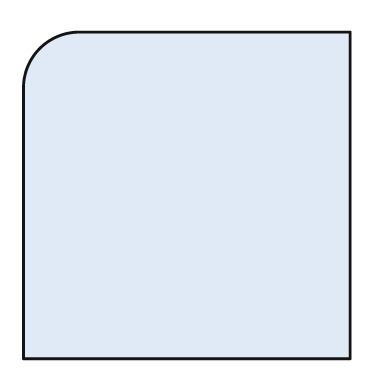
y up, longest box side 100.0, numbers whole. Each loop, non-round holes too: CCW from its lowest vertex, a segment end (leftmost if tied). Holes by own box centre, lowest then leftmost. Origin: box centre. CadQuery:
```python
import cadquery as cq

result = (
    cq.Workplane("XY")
    .moveTo(-50.0, -50.0)
    .lineTo(50.0, -50.0)
    .lineTo(50.0, 50.0)
    .lineTo(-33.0, 50.0)
    .threePointArc((-45.0, 45.0), (-50.0, 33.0))
    .close()
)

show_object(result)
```